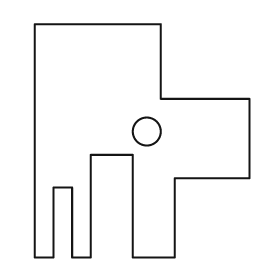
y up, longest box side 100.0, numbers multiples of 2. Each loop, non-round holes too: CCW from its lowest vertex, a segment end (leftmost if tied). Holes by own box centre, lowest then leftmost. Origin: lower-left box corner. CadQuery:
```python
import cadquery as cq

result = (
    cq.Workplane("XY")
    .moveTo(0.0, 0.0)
    .lineTo(8.0, 0.0)
    .lineTo(8.0, 30.0)
    .lineTo(16.0, 30.0)
    .lineTo(16.0, 0.0)
    .lineTo(24.0, 0.0)
    .lineTo(24.0, 44.0)
    .lineTo(42.0, 44.0)
    .lineTo(42.0, 0.0)
    .lineTo(60.0, 0.0)
    .lineTo(60.0, 34.0)
    .lineTo(92.0, 34.0)
    .lineTo(92.0, 68.0)
    .lineTo(54.0, 68.0)
    .lineTo(54.0, 100.0)
    .lineTo(0.0, 100.0)
    .close()
    .moveTo(48.0, 54.0)
    .circle(6.0)
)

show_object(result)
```